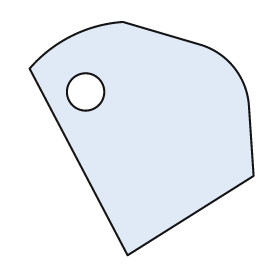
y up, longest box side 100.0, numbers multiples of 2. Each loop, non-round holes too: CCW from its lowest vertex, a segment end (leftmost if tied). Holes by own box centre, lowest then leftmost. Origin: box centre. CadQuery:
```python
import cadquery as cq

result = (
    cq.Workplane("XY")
    .moveTo(-6.0, -50.0)
    .lineTo(48.0, -16.0)
    .lineTo(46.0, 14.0)
    .threePointArc((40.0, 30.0), (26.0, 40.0))
    .lineTo(-8.0, 50.0)
    .threePointArc((-30.0, 44.0), (-48.0, 30.0))
    .close()
    .moveTo(-24.0, 20.0)
    .circle(8.0)
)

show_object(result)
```